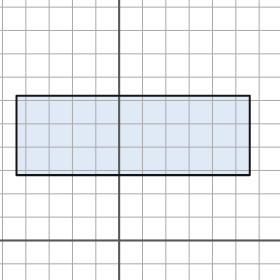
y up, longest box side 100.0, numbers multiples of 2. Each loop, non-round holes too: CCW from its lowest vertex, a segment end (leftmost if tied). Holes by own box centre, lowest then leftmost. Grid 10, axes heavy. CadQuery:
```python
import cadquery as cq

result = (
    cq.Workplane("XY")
    .moveTo(-44.0, 28.0)
    .lineTo(56.0, 28.0)
    .lineTo(56.0, 62.0)
    .lineTo(-44.0, 62.0)
    .close()
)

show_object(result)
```